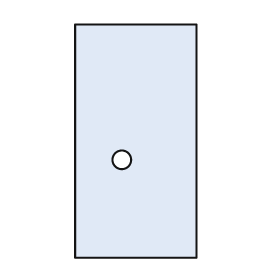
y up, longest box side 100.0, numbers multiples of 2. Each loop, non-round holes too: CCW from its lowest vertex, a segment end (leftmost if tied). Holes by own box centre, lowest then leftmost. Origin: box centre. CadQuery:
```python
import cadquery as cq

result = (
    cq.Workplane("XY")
    .moveTo(-26.0, -50.0)
    .lineTo(26.0, -50.0)
    .lineTo(26.0, 50.0)
    .lineTo(-26.0, 50.0)
    .close()
    .moveTo(-6.0, -8.0)
    .circle(4.0)
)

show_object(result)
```